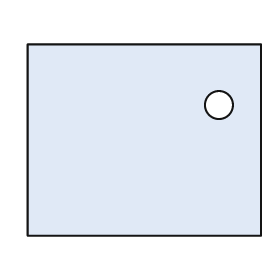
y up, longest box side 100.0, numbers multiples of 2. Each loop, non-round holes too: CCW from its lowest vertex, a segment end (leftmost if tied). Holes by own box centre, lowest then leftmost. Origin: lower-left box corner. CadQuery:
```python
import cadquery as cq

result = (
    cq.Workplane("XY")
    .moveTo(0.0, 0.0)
    .lineTo(100.0, 0.0)
    .lineTo(100.0, 82.0)
    .lineTo(0.0, 82.0)
    .close()
    .moveTo(82.0, 56.0)
    .circle(6.0)
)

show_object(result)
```